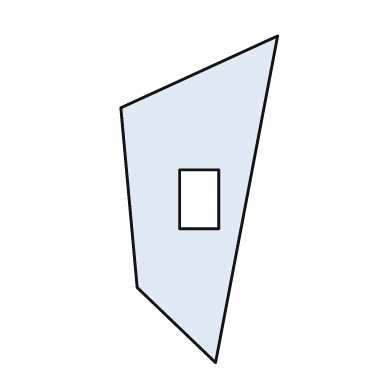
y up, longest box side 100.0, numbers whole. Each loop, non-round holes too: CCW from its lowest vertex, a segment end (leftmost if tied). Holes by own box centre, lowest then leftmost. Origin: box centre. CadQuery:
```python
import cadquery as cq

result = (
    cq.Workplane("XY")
    .moveTo(5.0, -50.0)
    .lineTo(24.0, 50.0)
    .lineTo(-24.0, 28.0)
    .lineTo(-19.0, -27.0)
    .close()
    .moveTo(-6.0, -9.0)
    .lineTo(6.0, -9.0)
    .lineTo(6.0, 9.0)
    .lineTo(-6.0, 9.0)
    .close()
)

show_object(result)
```